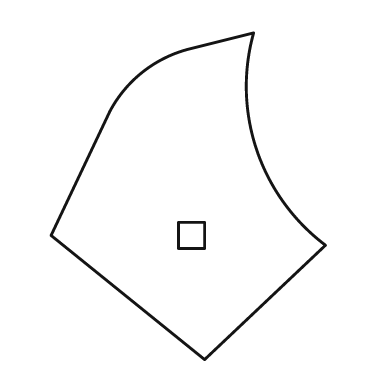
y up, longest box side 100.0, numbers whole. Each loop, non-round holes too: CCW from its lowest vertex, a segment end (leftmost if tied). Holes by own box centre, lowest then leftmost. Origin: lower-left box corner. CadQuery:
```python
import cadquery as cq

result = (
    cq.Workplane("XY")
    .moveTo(47.0, 0.0)
    .lineTo(84.0, 35.0)
    .threePointArc((63.0, 64.0), (62.0, 100.0))
    .lineTo(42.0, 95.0)
    .threePointArc((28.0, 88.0), (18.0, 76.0))
    .lineTo(0.0, 38.0)
    .close()
    .moveTo(39.0, 34.0)
    .lineTo(47.0, 34.0)
    .lineTo(47.0, 42.0)
    .lineTo(39.0, 42.0)
    .close()
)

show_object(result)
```